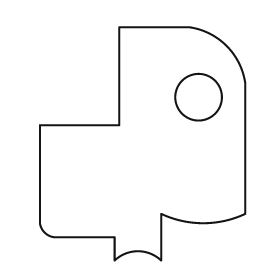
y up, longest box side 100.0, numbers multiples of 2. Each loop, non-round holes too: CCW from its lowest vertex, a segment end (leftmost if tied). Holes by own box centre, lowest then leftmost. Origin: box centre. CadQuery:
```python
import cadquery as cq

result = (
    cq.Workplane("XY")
    .moveTo(-12.0, -50.0)
    .threePointArc((-2.0, -46.0), (8.0, -50.0))
    .lineTo(8.0, -30.0)
    .threePointArc((26.0, -34.0), (44.0, -30.0))
    .lineTo(44.0, 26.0)
    .threePointArc((36.0, 42.0), (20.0, 50.0))
    .lineTo(-10.0, 50.0)
    .lineTo(-10.0, 8.0)
    .lineTo(-44.0, 8.0)
    .lineTo(-44.0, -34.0)
    .threePointArc((-42.0, -38.0), (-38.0, -40.0))
    .lineTo(-12.0, -40.0)
    .close()
    .moveTo(24.0, 20.0)
    .circle(10.0)
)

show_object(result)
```